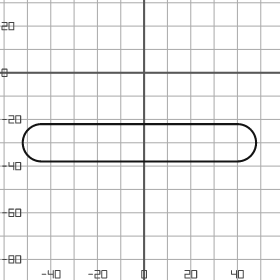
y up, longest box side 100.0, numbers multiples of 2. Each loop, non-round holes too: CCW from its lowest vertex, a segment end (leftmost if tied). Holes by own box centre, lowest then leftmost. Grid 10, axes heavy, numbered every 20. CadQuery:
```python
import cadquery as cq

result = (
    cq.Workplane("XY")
    .moveTo(-44.0, -38.0)
    .lineTo(40.0, -38.0)
    .threePointArc((48.0, -30.0), (40.0, -22.0))
    .lineTo(-44.0, -22.0)
    .threePointArc((-52.0, -30.0), (-44.0, -38.0))
    .close()
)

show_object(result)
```